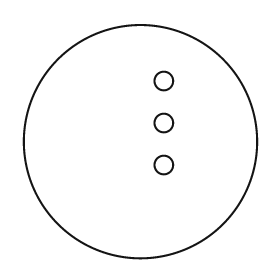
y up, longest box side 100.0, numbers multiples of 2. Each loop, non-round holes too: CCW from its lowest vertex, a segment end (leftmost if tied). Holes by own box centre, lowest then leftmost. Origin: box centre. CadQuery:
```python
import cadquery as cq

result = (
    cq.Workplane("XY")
    .moveTo(0.0, 0.0)
    .circle(50.0)
    .moveTo(10.0, -10.0)
    .circle(4.0)
    .moveTo(10.0, 8.0)
    .circle(4.0)
    .moveTo(10.0, 26.0)
    .circle(4.0)
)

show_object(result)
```